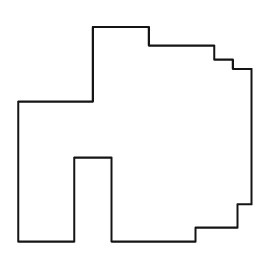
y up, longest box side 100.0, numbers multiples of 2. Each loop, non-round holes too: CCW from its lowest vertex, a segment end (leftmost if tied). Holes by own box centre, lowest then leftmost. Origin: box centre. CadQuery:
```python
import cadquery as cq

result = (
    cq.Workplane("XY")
    .moveTo(-50.0, -46.0)
    .lineTo(-26.0, -46.0)
    .lineTo(-26.0, -10.0)
    .lineTo(-10.0, -10.0)
    .lineTo(-10.0, -46.0)
    .lineTo(26.0, -46.0)
    .lineTo(26.0, -40.0)
    .lineTo(44.0, -40.0)
    .lineTo(44.0, -30.0)
    .lineTo(50.0, -30.0)
    .lineTo(50.0, 28.0)
    .lineTo(42.0, 28.0)
    .lineTo(42.0, 32.0)
    .lineTo(34.0, 32.0)
    .lineTo(34.0, 38.0)
    .lineTo(6.0, 38.0)
    .lineTo(6.0, 46.0)
    .lineTo(-18.0, 46.0)
    .lineTo(-18.0, 14.0)
    .lineTo(-50.0, 14.0)
    .close()
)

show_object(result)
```